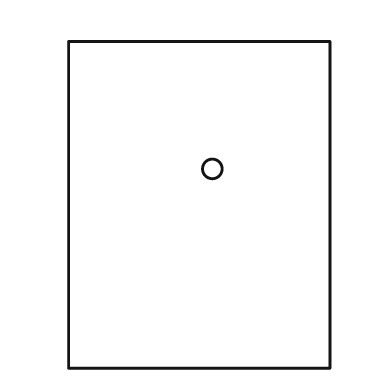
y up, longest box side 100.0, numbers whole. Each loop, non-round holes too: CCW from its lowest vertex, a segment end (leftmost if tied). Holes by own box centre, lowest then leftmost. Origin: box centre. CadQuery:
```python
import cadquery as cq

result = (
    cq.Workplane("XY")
    .moveTo(-40.0, -50.0)
    .lineTo(40.0, -50.0)
    .lineTo(40.0, 50.0)
    .lineTo(-40.0, 50.0)
    .close()
    .moveTo(4.0, 11.0)
    .circle(3.0)
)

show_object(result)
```